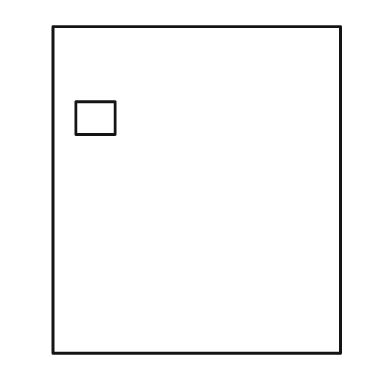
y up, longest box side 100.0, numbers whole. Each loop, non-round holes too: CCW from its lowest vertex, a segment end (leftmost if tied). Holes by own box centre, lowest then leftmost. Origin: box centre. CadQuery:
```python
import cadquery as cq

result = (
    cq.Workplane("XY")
    .moveTo(-44.0, -50.0)
    .lineTo(44.0, -50.0)
    .lineTo(44.0, 50.0)
    .lineTo(-44.0, 50.0)
    .close()
    .moveTo(-37.0, 17.0)
    .lineTo(-25.0, 17.0)
    .lineTo(-25.0, 27.0)
    .lineTo(-37.0, 27.0)
    .close()
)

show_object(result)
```